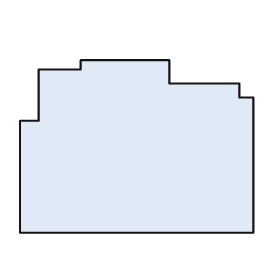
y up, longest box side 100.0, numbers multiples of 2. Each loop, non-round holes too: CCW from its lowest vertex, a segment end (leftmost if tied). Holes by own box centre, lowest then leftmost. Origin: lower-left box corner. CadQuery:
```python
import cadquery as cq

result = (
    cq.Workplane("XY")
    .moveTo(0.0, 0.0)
    .lineTo(100.0, 0.0)
    .lineTo(100.0, 58.0)
    .lineTo(94.0, 58.0)
    .lineTo(94.0, 64.0)
    .lineTo(64.0, 64.0)
    .lineTo(64.0, 74.0)
    .lineTo(26.0, 74.0)
    .lineTo(26.0, 70.0)
    .lineTo(8.0, 70.0)
    .lineTo(8.0, 48.0)
    .lineTo(0.0, 48.0)
    .close()
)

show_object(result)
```